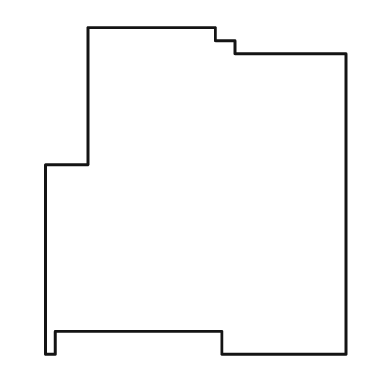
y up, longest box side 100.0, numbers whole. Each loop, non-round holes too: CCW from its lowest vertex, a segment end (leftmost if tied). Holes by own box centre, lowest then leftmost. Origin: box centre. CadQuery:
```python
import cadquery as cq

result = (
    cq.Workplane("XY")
    .moveTo(-46.0, -50.0)
    .lineTo(-43.0, -50.0)
    .lineTo(-43.0, -43.0)
    .lineTo(8.0, -43.0)
    .lineTo(8.0, -50.0)
    .lineTo(46.0, -50.0)
    .lineTo(46.0, 42.0)
    .lineTo(12.0, 42.0)
    .lineTo(12.0, 46.0)
    .lineTo(6.0, 46.0)
    .lineTo(6.0, 50.0)
    .lineTo(-33.0, 50.0)
    .lineTo(-33.0, 8.0)
    .lineTo(-46.0, 8.0)
    .close()
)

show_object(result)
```